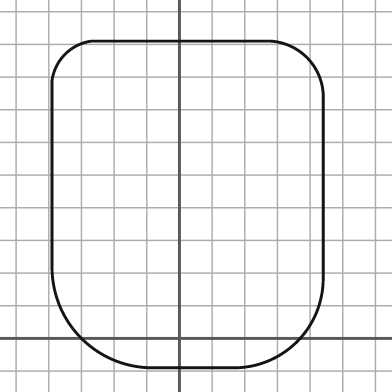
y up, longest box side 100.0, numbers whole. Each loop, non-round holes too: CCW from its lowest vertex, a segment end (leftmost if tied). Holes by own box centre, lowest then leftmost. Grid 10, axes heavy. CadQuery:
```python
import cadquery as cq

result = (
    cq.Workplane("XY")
    .moveTo(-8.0, -9.0)
    .lineTo(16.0, -9.0)
    .threePointArc((36.0, -1.0), (44.0, 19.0))
    .lineTo(44.0, 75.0)
    .threePointArc((39.0, 86.0), (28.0, 91.0))
    .lineTo(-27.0, 91.0)
    .threePointArc((-35.0, 87.0), (-39.0, 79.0))
    .lineTo(-39.0, 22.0)
    .threePointArc((-30.0, 0.0), (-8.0, -9.0))
    .close()
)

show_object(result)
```